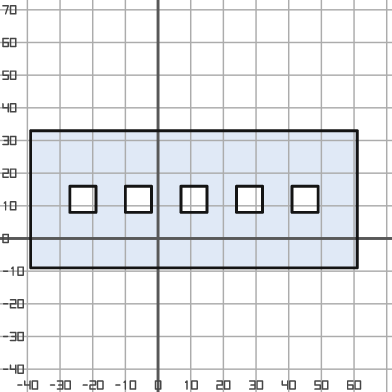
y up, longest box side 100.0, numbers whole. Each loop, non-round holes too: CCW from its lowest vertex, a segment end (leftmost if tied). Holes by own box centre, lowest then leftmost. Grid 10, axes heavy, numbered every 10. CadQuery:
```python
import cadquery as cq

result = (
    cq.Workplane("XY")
    .moveTo(-39.0, -9.0)
    .lineTo(61.0, -9.0)
    .lineTo(61.0, 33.0)
    .lineTo(-39.0, 33.0)
    .close()
    .moveTo(-27.0, 8.0)
    .lineTo(-19.0, 8.0)
    .lineTo(-19.0, 16.0)
    .lineTo(-27.0, 16.0)
    .close()
    .moveTo(-10.0, 8.0)
    .lineTo(-2.0, 8.0)
    .lineTo(-2.0, 16.0)
    .lineTo(-10.0, 16.0)
    .close()
    .moveTo(7.0, 8.0)
    .lineTo(15.0, 8.0)
    .lineTo(15.0, 16.0)
    .lineTo(7.0, 16.0)
    .close()
    .moveTo(24.0, 8.0)
    .lineTo(32.0, 8.0)
    .lineTo(32.0, 16.0)
    .lineTo(24.0, 16.0)
    .close()
    .moveTo(41.0, 8.0)
    .lineTo(49.0, 8.0)
    .lineTo(49.0, 16.0)
    .lineTo(41.0, 16.0)
    .close()
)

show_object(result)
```